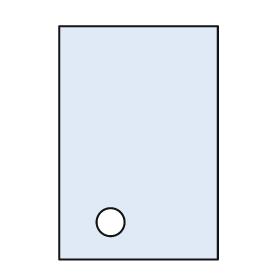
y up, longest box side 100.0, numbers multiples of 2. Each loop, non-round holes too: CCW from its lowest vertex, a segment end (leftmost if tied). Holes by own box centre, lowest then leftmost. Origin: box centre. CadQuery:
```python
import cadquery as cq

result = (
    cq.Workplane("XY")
    .moveTo(-34.0, -50.0)
    .lineTo(34.0, -50.0)
    .lineTo(34.0, 50.0)
    .lineTo(-34.0, 50.0)
    .close()
    .moveTo(-12.0, -34.0)
    .circle(6.0)
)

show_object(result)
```